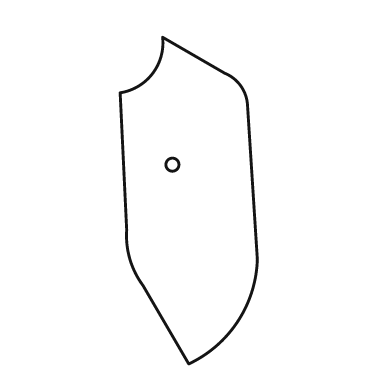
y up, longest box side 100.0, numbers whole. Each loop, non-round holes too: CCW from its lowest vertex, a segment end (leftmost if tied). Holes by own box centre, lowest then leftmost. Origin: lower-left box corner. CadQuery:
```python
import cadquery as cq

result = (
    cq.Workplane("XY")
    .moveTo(21.0, 0.0)
    .threePointArc((36.0, 13.0), (42.0, 32.0))
    .lineTo(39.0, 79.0)
    .threePointArc((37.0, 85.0), (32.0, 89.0))
    .lineTo(13.0, 100.0)
    .threePointArc((10.0, 89.0), (0.0, 83.0))
    .lineTo(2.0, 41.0)
    .threePointArc((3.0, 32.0), (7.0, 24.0))
    .close()
    .moveTo(16.0, 61.0)
    .circle(2.0)
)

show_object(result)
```